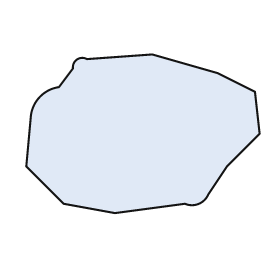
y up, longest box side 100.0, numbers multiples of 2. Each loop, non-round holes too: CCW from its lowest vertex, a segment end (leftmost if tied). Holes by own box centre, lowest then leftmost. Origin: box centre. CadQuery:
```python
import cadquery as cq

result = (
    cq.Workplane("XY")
    .moveTo(-12.0, -34.0)
    .lineTo(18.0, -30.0)
    .threePointArc((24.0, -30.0), (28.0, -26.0))
    .lineTo(36.0, -14.0)
    .lineTo(50.0, 0.0)
    .lineTo(48.0, 18.0)
    .lineTo(32.0, 26.0)
    .lineTo(4.0, 34.0)
    .lineTo(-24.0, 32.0)
    .threePointArc((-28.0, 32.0), (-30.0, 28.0))
    .lineTo(-36.0, 20.0)
    .threePointArc((-44.0, 16.0), (-48.0, 8.0))
    .lineTo(-50.0, -14.0)
    .lineTo(-34.0, -30.0)
    .close()
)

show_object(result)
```